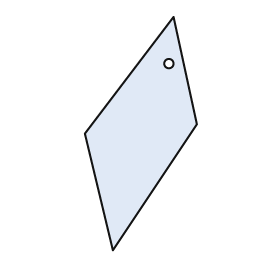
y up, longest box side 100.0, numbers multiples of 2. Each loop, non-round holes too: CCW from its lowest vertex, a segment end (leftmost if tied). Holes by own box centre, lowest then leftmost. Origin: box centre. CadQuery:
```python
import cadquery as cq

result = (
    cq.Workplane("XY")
    .moveTo(-12.0, -50.0)
    .lineTo(24.0, 4.0)
    .lineTo(14.0, 50.0)
    .lineTo(-24.0, 0.0)
    .close()
    .moveTo(12.0, 30.0)
    .circle(2.0)
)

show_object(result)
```